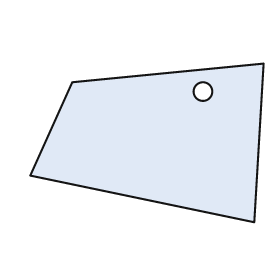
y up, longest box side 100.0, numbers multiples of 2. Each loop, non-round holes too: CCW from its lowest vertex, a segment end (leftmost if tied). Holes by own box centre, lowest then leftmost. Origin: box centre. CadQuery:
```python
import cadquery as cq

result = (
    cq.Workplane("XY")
    .moveTo(46.0, -34.0)
    .lineTo(50.0, 34.0)
    .lineTo(-32.0, 26.0)
    .lineTo(-50.0, -14.0)
    .close()
    .moveTo(24.0, 22.0)
    .circle(4.0)
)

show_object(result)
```